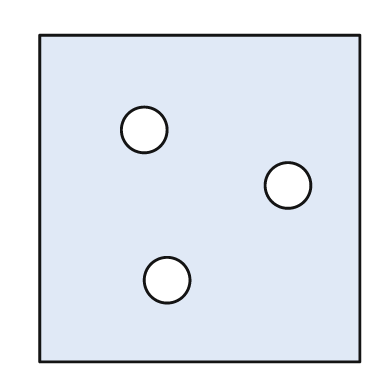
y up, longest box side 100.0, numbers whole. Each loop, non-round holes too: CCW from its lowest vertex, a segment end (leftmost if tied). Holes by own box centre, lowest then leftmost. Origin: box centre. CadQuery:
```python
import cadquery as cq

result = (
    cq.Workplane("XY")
    .moveTo(-49.0, -50.0)
    .lineTo(49.0, -50.0)
    .lineTo(49.0, 50.0)
    .lineTo(-49.0, 50.0)
    .close()
    .moveTo(-10.0, -25.0)
    .circle(7.0)
    .moveTo(27.0, 4.0)
    .circle(7.0)
    .moveTo(-17.0, 21.0)
    .circle(7.0)
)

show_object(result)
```